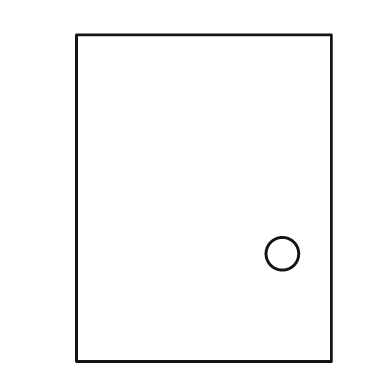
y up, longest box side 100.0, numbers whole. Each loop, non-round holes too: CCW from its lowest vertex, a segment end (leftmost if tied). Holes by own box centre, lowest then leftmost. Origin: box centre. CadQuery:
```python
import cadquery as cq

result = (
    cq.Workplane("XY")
    .moveTo(-39.0, -50.0)
    .lineTo(39.0, -50.0)
    .lineTo(39.0, 50.0)
    .lineTo(-39.0, 50.0)
    .close()
    .moveTo(24.0, -17.0)
    .circle(5.0)
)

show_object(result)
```